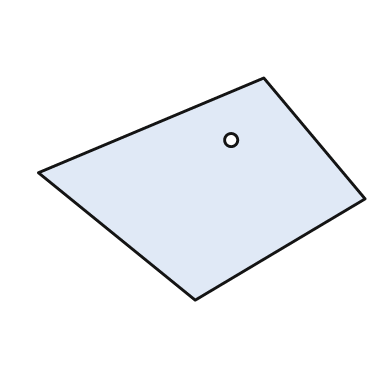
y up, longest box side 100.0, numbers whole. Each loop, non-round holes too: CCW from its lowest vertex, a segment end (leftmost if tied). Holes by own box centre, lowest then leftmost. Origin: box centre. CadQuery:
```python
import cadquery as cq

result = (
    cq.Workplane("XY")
    .moveTo(-2.0, -34.0)
    .lineTo(50.0, -3.0)
    .lineTo(19.0, 34.0)
    .lineTo(-50.0, 5.0)
    .close()
    .moveTo(9.0, 15.0)
    .circle(2.0)
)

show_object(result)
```